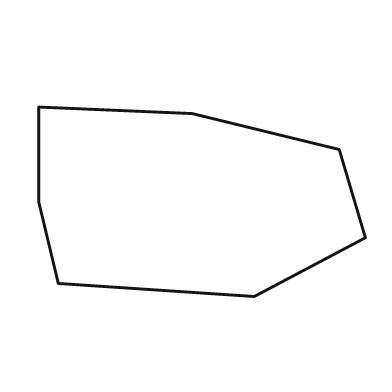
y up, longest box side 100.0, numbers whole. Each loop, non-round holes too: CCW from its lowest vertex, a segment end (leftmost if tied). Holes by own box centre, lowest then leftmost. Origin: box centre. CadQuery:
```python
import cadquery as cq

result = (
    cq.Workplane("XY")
    .moveTo(16.0, -29.0)
    .lineTo(50.0, -11.0)
    .lineTo(42.0, 16.0)
    .lineTo(-3.0, 27.0)
    .lineTo(-50.0, 29.0)
    .lineTo(-50.0, 0.0)
    .lineTo(-44.0, -25.0)
    .close()
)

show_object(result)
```